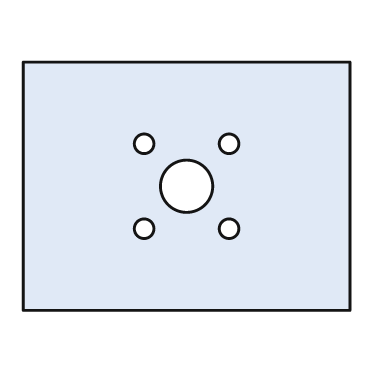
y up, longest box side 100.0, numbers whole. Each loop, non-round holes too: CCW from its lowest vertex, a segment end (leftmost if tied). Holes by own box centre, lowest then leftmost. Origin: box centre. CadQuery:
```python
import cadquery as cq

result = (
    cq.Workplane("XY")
    .moveTo(-50.0, -38.0)
    .lineTo(50.0, -38.0)
    .lineTo(50.0, 38.0)
    .lineTo(-50.0, 38.0)
    .close()
    .moveTo(-13.0, -13.0)
    .circle(3.0)
    .moveTo(13.0, -13.0)
    .circle(3.0)
    .moveTo(0.0, 0.0)
    .circle(8.0)
    .moveTo(-13.0, 13.0)
    .circle(3.0)
    .moveTo(13.0, 13.0)
    .circle(3.0)
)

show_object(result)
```